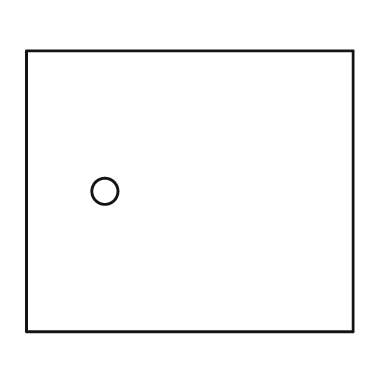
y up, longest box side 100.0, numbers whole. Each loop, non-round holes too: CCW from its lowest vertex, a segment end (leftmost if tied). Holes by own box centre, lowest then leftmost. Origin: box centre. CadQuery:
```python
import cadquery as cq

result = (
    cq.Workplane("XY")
    .moveTo(-50.0, -43.0)
    .lineTo(50.0, -43.0)
    .lineTo(50.0, 43.0)
    .lineTo(-50.0, 43.0)
    .close()
    .moveTo(-26.0, 0.0)
    .circle(4.0)
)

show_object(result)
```